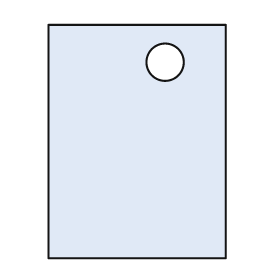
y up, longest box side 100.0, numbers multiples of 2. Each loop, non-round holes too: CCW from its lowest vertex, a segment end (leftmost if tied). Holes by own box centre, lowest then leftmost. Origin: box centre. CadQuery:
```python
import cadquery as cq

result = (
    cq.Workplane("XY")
    .moveTo(-38.0, -50.0)
    .lineTo(38.0, -50.0)
    .lineTo(38.0, 50.0)
    .lineTo(-38.0, 50.0)
    .close()
    .moveTo(12.0, 34.0)
    .circle(8.0)
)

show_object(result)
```